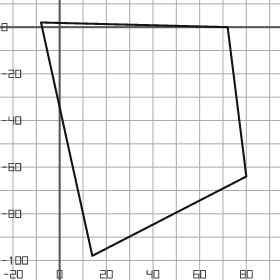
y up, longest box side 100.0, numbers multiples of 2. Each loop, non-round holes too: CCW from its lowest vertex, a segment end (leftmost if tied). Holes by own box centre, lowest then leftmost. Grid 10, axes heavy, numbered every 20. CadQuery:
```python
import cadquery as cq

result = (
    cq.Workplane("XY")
    .moveTo(14.0, -98.0)
    .lineTo(80.0, -64.0)
    .lineTo(72.0, 0.0)
    .lineTo(-8.0, 2.0)
    .close()
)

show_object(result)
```